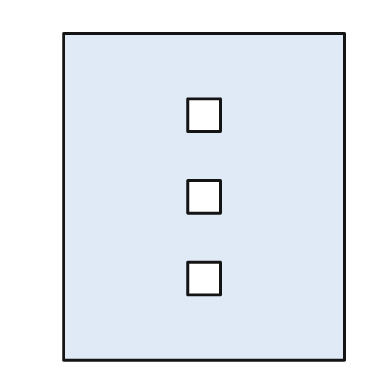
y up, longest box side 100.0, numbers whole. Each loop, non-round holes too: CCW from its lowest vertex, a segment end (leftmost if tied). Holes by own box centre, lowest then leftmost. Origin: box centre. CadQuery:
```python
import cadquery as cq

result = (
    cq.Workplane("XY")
    .moveTo(-43.0, -50.0)
    .lineTo(43.0, -50.0)
    .lineTo(43.0, 50.0)
    .lineTo(-43.0, 50.0)
    .close()
    .moveTo(-5.0, -30.0)
    .lineTo(5.0, -30.0)
    .lineTo(5.0, -20.0)
    .lineTo(-5.0, -20.0)
    .close()
    .moveTo(-5.0, -5.0)
    .lineTo(5.0, -5.0)
    .lineTo(5.0, 5.0)
    .lineTo(-5.0, 5.0)
    .close()
    .moveTo(-5.0, 20.0)
    .lineTo(5.0, 20.0)
    .lineTo(5.0, 30.0)
    .lineTo(-5.0, 30.0)
    .close()
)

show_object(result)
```